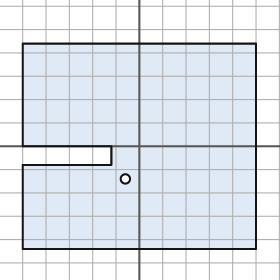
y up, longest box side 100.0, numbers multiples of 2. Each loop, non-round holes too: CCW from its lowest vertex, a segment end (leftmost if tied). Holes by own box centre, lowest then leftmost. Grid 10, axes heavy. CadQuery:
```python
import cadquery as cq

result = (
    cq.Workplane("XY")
    .moveTo(-50.0, -44.0)
    .lineTo(50.0, -44.0)
    .lineTo(50.0, 44.0)
    .lineTo(-50.0, 44.0)
    .lineTo(-50.0, 0.0)
    .lineTo(-12.0, 0.0)
    .lineTo(-12.0, -8.0)
    .lineTo(-50.0, -8.0)
    .close()
    .moveTo(-6.0, -14.0)
    .circle(2.0)
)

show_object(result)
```